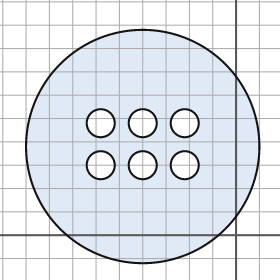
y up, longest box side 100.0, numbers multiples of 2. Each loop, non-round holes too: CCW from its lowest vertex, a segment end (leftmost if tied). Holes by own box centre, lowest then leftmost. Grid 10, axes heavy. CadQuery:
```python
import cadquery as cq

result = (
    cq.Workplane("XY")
    .moveTo(-40.0, 38.0)
    .circle(50.0)
    .moveTo(-58.0, 30.0)
    .circle(6.0)
    .moveTo(-40.0, 30.0)
    .circle(6.0)
    .moveTo(-22.0, 30.0)
    .circle(6.0)
    .moveTo(-58.0, 48.0)
    .circle(6.0)
    .moveTo(-40.0, 48.0)
    .circle(6.0)
    .moveTo(-22.0, 48.0)
    .circle(6.0)
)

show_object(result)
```